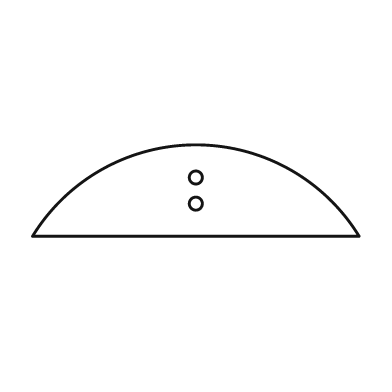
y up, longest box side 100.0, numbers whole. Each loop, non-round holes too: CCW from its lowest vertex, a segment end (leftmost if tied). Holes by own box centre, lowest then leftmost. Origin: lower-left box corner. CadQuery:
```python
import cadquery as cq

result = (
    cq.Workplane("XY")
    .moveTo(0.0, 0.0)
    .lineTo(100.0, 0.0)
    .threePointArc((50.0, 28.0), (0.0, 0.0))
    .close()
    .moveTo(50.0, 10.0)
    .circle(2.0)
    .moveTo(50.0, 18.0)
    .circle(2.0)
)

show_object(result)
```